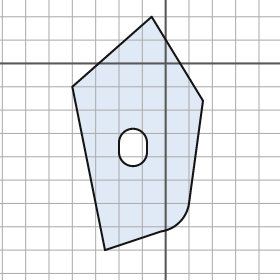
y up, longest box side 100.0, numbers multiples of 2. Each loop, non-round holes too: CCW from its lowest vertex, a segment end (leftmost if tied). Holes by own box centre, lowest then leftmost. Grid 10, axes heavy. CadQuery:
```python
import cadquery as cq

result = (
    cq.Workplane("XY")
    .moveTo(-26.0, -80.0)
    .lineTo(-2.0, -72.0)
    .threePointArc((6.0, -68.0), (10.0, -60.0))
    .lineTo(16.0, -16.0)
    .lineTo(-6.0, 20.0)
    .lineTo(-40.0, -10.0)
    .close()
    .moveTo(-20.0, -38.0)
    .threePointArc((-14.0, -44.0), (-8.0, -38.0))
    .lineTo(-8.0, -34.0)
    .threePointArc((-14.0, -28.0), (-20.0, -34.0))
    .close()
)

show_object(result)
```